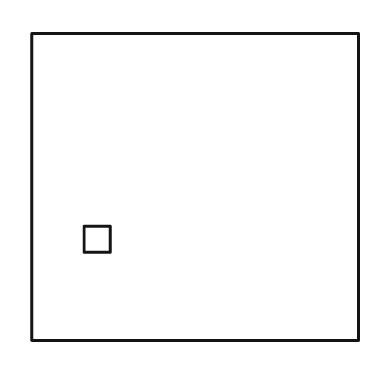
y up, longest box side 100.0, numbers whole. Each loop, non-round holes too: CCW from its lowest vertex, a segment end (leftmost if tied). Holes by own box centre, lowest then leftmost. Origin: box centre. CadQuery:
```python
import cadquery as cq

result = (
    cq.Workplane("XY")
    .moveTo(-50.0, -47.0)
    .lineTo(50.0, -47.0)
    .lineTo(50.0, 47.0)
    .lineTo(-50.0, 47.0)
    .close()
    .moveTo(-34.0, -20.0)
    .lineTo(-26.0, -20.0)
    .lineTo(-26.0, -12.0)
    .lineTo(-34.0, -12.0)
    .close()
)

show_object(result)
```